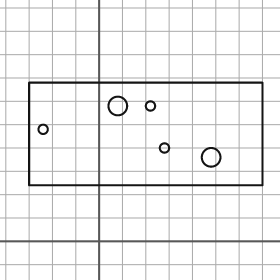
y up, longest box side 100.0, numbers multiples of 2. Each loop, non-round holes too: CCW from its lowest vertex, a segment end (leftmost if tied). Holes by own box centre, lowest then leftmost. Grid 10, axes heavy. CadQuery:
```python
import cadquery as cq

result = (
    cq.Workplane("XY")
    .moveTo(-30.0, 24.0)
    .lineTo(70.0, 24.0)
    .lineTo(70.0, 68.0)
    .lineTo(-30.0, 68.0)
    .close()
    .moveTo(48.0, 36.0)
    .circle(4.0)
    .moveTo(28.0, 40.0)
    .circle(2.0)
    .moveTo(-24.0, 48.0)
    .circle(2.0)
    .moveTo(8.0, 58.0)
    .circle(4.0)
    .moveTo(22.0, 58.0)
    .circle(2.0)
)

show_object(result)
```